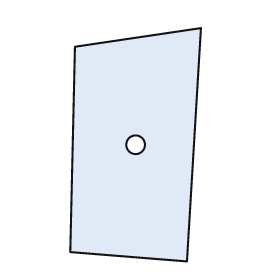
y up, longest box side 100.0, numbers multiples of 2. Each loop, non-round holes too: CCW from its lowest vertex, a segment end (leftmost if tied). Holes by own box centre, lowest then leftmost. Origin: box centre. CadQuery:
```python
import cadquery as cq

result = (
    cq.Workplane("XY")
    .moveTo(22.0, -50.0)
    .lineTo(28.0, 50.0)
    .lineTo(-26.0, 42.0)
    .lineTo(-28.0, -46.0)
    .close()
    .moveTo(0.0, 0.0)
    .circle(4.0)
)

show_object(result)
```